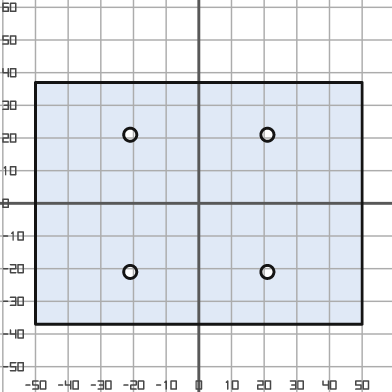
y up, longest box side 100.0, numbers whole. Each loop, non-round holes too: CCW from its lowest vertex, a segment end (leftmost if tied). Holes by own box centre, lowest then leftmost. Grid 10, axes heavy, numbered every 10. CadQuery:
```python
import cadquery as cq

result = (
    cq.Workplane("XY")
    .moveTo(-50.0, -37.0)
    .lineTo(50.0, -37.0)
    .lineTo(50.0, 37.0)
    .lineTo(-50.0, 37.0)
    .close()
    .moveTo(-21.0, -21.0)
    .circle(2.0)
    .moveTo(21.0, -21.0)
    .circle(2.0)
    .moveTo(-21.0, 21.0)
    .circle(2.0)
    .moveTo(21.0, 21.0)
    .circle(2.0)
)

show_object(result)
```